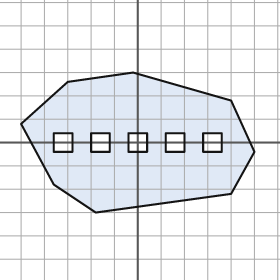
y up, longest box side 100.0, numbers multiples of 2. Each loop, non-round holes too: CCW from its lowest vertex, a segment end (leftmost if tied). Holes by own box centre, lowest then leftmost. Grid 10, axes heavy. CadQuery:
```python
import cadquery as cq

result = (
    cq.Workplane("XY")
    .moveTo(-18.0, -30.0)
    .lineTo(40.0, -22.0)
    .lineTo(50.0, -4.0)
    .lineTo(40.0, 18.0)
    .lineTo(-2.0, 30.0)
    .lineTo(-30.0, 26.0)
    .lineTo(-50.0, 8.0)
    .lineTo(-36.0, -18.0)
    .close()
    .moveTo(-36.0, -4.0)
    .lineTo(-28.0, -4.0)
    .lineTo(-28.0, 4.0)
    .lineTo(-36.0, 4.0)
    .close()
    .moveTo(-20.0, -4.0)
    .lineTo(-12.0, -4.0)
    .lineTo(-12.0, 4.0)
    .lineTo(-20.0, 4.0)
    .close()
    .moveTo(-4.0, -4.0)
    .lineTo(4.0, -4.0)
    .lineTo(4.0, 4.0)
    .lineTo(-4.0, 4.0)
    .close()
    .moveTo(12.0, -4.0)
    .lineTo(20.0, -4.0)
    .lineTo(20.0, 4.0)
    .lineTo(12.0, 4.0)
    .close()
    .moveTo(28.0, -4.0)
    .lineTo(36.0, -4.0)
    .lineTo(36.0, 4.0)
    .lineTo(28.0, 4.0)
    .close()
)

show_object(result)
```